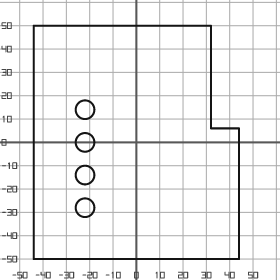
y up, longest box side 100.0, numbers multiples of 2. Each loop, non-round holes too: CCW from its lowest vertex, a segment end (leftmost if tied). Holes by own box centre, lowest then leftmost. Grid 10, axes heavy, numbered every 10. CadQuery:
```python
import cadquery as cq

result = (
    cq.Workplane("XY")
    .moveTo(-44.0, -50.0)
    .lineTo(44.0, -50.0)
    .lineTo(44.0, 6.0)
    .lineTo(32.0, 6.0)
    .lineTo(32.0, 50.0)
    .lineTo(-44.0, 50.0)
    .close()
    .moveTo(-22.0, -28.0)
    .circle(4.0)
    .moveTo(-22.0, -14.0)
    .circle(4.0)
    .moveTo(-22.0, 0.0)
    .circle(4.0)
    .moveTo(-22.0, 14.0)
    .circle(4.0)
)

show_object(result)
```